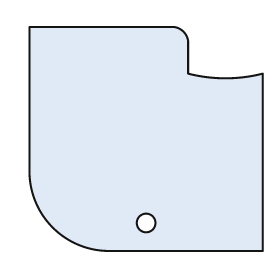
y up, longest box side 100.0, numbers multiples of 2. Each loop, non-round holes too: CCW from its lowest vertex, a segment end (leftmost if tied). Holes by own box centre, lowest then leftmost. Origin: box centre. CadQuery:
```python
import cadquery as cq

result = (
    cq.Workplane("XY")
    .moveTo(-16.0, -48.0)
    .lineTo(50.0, -48.0)
    .lineTo(50.0, 28.0)
    .threePointArc((34.0, 26.0), (18.0, 28.0))
    .lineTo(18.0, 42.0)
    .threePointArc((16.0, 46.0), (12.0, 48.0))
    .lineTo(-50.0, 48.0)
    .lineTo(-50.0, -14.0)
    .threePointArc((-40.0, -38.0), (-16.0, -48.0))
    .close()
    .moveTo(0.0, -36.0)
    .circle(4.0)
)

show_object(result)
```